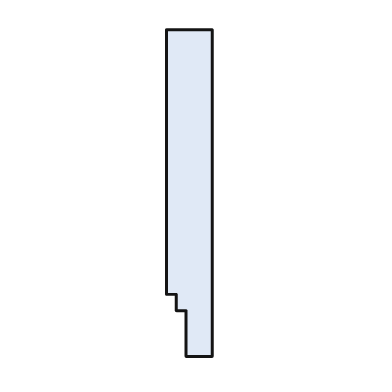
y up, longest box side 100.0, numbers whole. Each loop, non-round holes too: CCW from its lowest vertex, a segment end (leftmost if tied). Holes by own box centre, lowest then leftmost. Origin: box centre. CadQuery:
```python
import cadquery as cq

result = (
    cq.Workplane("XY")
    .moveTo(-1.0, -50.0)
    .lineTo(7.0, -50.0)
    .lineTo(7.0, 50.0)
    .lineTo(-7.0, 50.0)
    .lineTo(-7.0, -31.0)
    .lineTo(-4.0, -31.0)
    .lineTo(-4.0, -36.0)
    .lineTo(-1.0, -36.0)
    .close()
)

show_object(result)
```